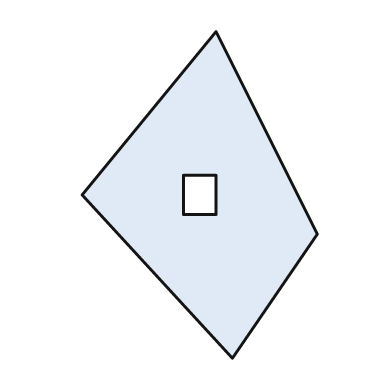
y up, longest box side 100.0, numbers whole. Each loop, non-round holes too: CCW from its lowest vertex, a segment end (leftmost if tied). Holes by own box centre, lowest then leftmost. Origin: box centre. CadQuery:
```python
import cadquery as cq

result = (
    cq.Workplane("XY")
    .moveTo(10.0, -50.0)
    .lineTo(36.0, -12.0)
    .lineTo(5.0, 50.0)
    .lineTo(-36.0, 0.0)
    .close()
    .moveTo(-5.0, -6.0)
    .lineTo(5.0, -6.0)
    .lineTo(5.0, 6.0)
    .lineTo(-5.0, 6.0)
    .close()
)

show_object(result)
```